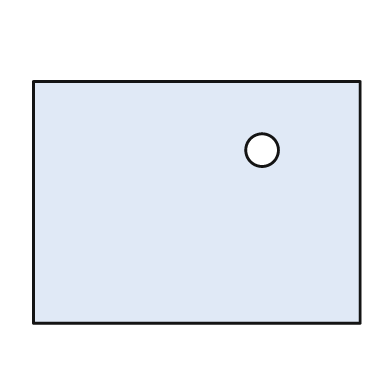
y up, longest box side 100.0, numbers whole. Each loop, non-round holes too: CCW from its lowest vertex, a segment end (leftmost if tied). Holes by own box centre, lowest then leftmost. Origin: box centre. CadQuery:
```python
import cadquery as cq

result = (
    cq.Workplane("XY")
    .moveTo(-50.0, -37.0)
    .lineTo(50.0, -37.0)
    .lineTo(50.0, 37.0)
    .lineTo(-50.0, 37.0)
    .close()
    .moveTo(20.0, 16.0)
    .circle(5.0)
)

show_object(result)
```